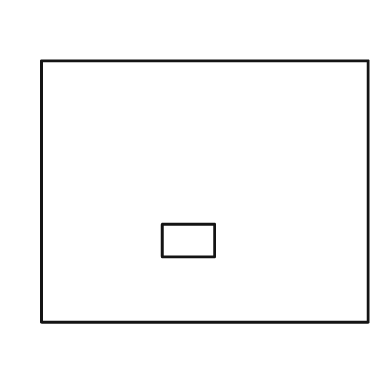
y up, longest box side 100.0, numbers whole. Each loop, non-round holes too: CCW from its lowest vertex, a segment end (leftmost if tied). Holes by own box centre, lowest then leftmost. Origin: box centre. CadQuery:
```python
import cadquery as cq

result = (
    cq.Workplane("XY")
    .moveTo(-50.0, -40.0)
    .lineTo(50.0, -40.0)
    .lineTo(50.0, 40.0)
    .lineTo(-50.0, 40.0)
    .close()
    .moveTo(-13.0, -20.0)
    .lineTo(3.0, -20.0)
    .lineTo(3.0, -10.0)
    .lineTo(-13.0, -10.0)
    .close()
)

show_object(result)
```